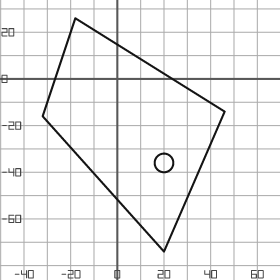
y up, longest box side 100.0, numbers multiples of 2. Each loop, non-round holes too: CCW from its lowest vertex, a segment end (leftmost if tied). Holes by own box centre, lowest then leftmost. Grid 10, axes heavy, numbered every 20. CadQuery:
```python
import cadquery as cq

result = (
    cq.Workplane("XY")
    .moveTo(20.0, -74.0)
    .lineTo(46.0, -14.0)
    .lineTo(-18.0, 26.0)
    .lineTo(-32.0, -16.0)
    .close()
    .moveTo(20.0, -36.0)
    .circle(4.0)
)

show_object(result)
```